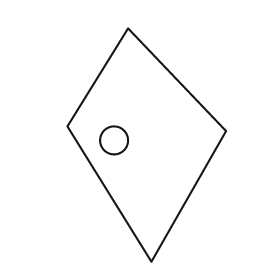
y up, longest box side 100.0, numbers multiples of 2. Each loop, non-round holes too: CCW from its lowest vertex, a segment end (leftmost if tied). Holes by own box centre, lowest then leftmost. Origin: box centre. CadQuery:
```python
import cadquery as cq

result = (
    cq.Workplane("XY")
    .moveTo(2.0, -50.0)
    .lineTo(34.0, 6.0)
    .lineTo(-8.0, 50.0)
    .lineTo(-34.0, 8.0)
    .close()
    .moveTo(-14.0, 2.0)
    .circle(6.0)
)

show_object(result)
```